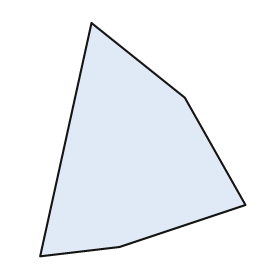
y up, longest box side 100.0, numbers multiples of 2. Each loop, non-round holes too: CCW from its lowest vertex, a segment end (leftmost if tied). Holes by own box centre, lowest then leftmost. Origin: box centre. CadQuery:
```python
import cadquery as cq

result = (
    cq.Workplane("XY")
    .moveTo(-44.0, -50.0)
    .lineTo(-10.0, -46.0)
    .lineTo(44.0, -28.0)
    .lineTo(18.0, 18.0)
    .lineTo(-22.0, 50.0)
    .close()
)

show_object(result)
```